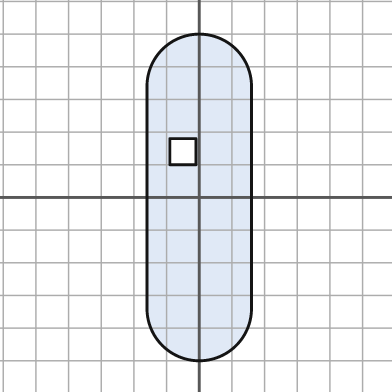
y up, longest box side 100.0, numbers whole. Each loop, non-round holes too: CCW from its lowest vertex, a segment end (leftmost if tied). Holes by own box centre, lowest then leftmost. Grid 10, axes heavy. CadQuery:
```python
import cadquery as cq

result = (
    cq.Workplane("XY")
    .moveTo(-16.0, -34.0)
    .threePointArc((0.0, -50.0), (16.0, -34.0))
    .lineTo(16.0, 34.0)
    .threePointArc((0.0, 50.0), (-16.0, 34.0))
    .close()
    .moveTo(-9.0, 10.0)
    .lineTo(-1.0, 10.0)
    .lineTo(-1.0, 18.0)
    .lineTo(-9.0, 18.0)
    .close()
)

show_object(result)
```